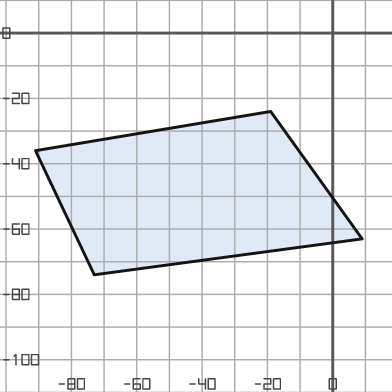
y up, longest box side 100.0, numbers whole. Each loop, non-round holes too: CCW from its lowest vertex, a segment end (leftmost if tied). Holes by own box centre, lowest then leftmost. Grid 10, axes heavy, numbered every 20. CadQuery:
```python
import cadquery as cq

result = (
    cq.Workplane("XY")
    .moveTo(-73.0, -74.0)
    .lineTo(9.0, -63.0)
    .lineTo(-19.0, -24.0)
    .lineTo(-91.0, -36.0)
    .close()
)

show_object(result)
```